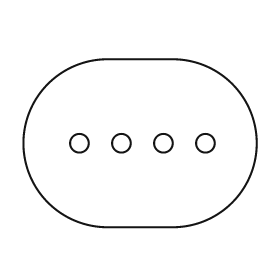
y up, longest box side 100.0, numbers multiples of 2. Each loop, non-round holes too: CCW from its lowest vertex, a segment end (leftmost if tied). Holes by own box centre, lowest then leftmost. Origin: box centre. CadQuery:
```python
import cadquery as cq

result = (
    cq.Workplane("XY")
    .moveTo(-14.0, -36.0)
    .lineTo(14.0, -36.0)
    .threePointArc((50.0, 0.0), (14.0, 36.0))
    .lineTo(-14.0, 36.0)
    .threePointArc((-50.0, 0.0), (-14.0, -36.0))
    .close()
    .moveTo(-26.0, 0.0)
    .circle(4.0)
    .moveTo(-8.0, 0.0)
    .circle(4.0)
    .moveTo(10.0, 0.0)
    .circle(4.0)
    .moveTo(28.0, 0.0)
    .circle(4.0)
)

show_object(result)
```